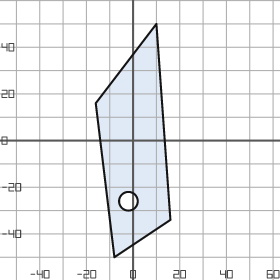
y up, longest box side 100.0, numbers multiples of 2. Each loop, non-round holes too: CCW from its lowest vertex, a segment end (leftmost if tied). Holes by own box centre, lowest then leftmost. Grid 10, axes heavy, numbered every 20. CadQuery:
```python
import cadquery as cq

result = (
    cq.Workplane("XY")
    .moveTo(-8.0, -50.0)
    .lineTo(16.0, -34.0)
    .lineTo(10.0, 50.0)
    .lineTo(-16.0, 16.0)
    .close()
    .moveTo(-2.0, -26.0)
    .circle(4.0)
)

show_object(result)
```